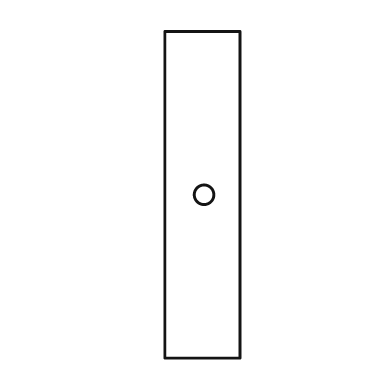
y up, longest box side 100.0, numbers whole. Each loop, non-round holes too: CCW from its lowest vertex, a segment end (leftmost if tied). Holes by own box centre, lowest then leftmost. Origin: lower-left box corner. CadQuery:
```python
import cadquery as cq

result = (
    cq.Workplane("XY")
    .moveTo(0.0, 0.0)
    .lineTo(23.0, 0.0)
    .lineTo(23.0, 100.0)
    .lineTo(0.0, 100.0)
    .close()
    .moveTo(12.0, 50.0)
    .circle(3.0)
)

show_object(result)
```